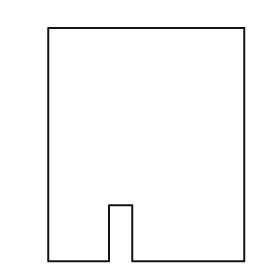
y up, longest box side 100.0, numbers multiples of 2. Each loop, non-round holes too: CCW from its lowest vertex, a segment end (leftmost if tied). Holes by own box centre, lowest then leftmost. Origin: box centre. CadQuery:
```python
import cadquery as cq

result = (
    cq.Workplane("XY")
    .moveTo(-42.0, -50.0)
    .lineTo(-16.0, -50.0)
    .lineTo(-16.0, -26.0)
    .lineTo(-6.0, -26.0)
    .lineTo(-6.0, -50.0)
    .lineTo(42.0, -50.0)
    .lineTo(42.0, 50.0)
    .lineTo(-42.0, 50.0)
    .close()
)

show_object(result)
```